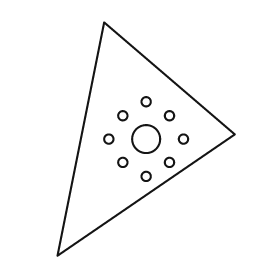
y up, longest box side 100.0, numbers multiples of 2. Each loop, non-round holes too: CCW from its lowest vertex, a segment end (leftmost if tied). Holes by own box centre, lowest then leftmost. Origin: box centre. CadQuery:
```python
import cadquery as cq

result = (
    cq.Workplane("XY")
    .moveTo(-38.0, -50.0)
    .lineTo(38.0, 2.0)
    .lineTo(-18.0, 50.0)
    .close()
    .moveTo(0.0, -16.0)
    .circle(2.0)
    .moveTo(-10.0, -10.0)
    .circle(2.0)
    .moveTo(10.0, -10.0)
    .circle(2.0)
    .moveTo(-16.0, 0.0)
    .circle(2.0)
    .moveTo(0.0, 0.0)
    .circle(6.0)
    .moveTo(16.0, 0.0)
    .circle(2.0)
    .moveTo(-10.0, 10.0)
    .circle(2.0)
    .moveTo(10.0, 10.0)
    .circle(2.0)
    .moveTo(0.0, 16.0)
    .circle(2.0)
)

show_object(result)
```